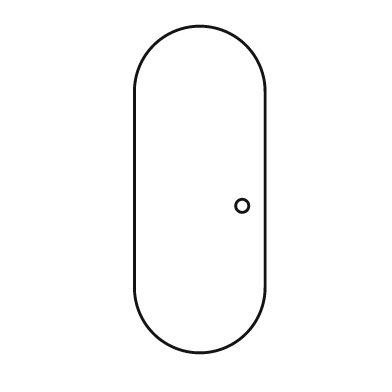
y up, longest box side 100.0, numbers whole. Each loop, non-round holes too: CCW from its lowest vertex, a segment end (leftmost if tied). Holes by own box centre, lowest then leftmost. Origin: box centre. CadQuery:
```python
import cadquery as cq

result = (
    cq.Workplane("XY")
    .moveTo(-20.0, -30.0)
    .threePointArc((0.0, -50.0), (20.0, -30.0))
    .lineTo(20.0, 30.0)
    .threePointArc((0.0, 50.0), (-20.0, 30.0))
    .close()
    .moveTo(13.0, -5.0)
    .circle(2.0)
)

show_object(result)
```